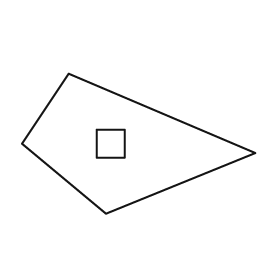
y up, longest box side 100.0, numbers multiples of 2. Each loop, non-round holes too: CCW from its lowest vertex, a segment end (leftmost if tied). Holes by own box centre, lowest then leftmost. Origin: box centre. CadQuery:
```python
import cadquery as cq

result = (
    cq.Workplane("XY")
    .moveTo(-14.0, -30.0)
    .lineTo(50.0, -4.0)
    .lineTo(-30.0, 30.0)
    .lineTo(-50.0, 0.0)
    .close()
    .moveTo(-18.0, -6.0)
    .lineTo(-6.0, -6.0)
    .lineTo(-6.0, 6.0)
    .lineTo(-18.0, 6.0)
    .close()
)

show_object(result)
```